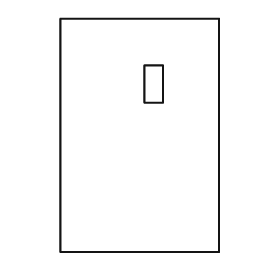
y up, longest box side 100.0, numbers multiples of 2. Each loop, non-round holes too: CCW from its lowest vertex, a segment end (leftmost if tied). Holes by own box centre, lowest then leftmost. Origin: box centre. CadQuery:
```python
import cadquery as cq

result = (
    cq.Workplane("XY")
    .moveTo(-34.0, -50.0)
    .lineTo(34.0, -50.0)
    .lineTo(34.0, 50.0)
    .lineTo(-34.0, 50.0)
    .close()
    .moveTo(2.0, 14.0)
    .lineTo(10.0, 14.0)
    .lineTo(10.0, 30.0)
    .lineTo(2.0, 30.0)
    .close()
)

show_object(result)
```